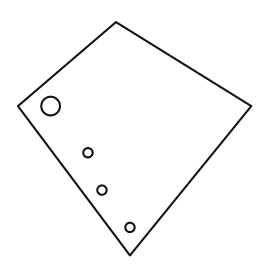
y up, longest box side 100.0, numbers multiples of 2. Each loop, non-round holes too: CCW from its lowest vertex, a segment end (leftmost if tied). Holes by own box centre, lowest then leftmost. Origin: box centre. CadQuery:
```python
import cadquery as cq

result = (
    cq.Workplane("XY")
    .moveTo(-2.0, -50.0)
    .lineTo(50.0, 14.0)
    .lineTo(-8.0, 50.0)
    .lineTo(-50.0, 14.0)
    .close()
    .moveTo(-2.0, -38.0)
    .circle(2.0)
    .moveTo(-14.0, -22.0)
    .circle(2.0)
    .moveTo(-20.0, -6.0)
    .circle(2.0)
    .moveTo(-36.0, 14.0)
    .circle(4.0)
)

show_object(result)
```